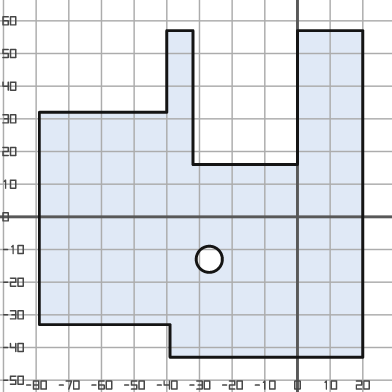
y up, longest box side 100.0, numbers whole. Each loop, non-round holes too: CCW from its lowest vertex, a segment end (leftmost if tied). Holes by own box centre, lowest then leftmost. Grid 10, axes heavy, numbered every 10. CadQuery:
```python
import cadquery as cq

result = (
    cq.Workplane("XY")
    .moveTo(-39.0, -43.0)
    .lineTo(20.0, -43.0)
    .lineTo(20.0, 57.0)
    .lineTo(0.0, 57.0)
    .lineTo(0.0, 16.0)
    .lineTo(-32.0, 16.0)
    .lineTo(-32.0, 57.0)
    .lineTo(-40.0, 57.0)
    .lineTo(-40.0, 32.0)
    .lineTo(-79.0, 32.0)
    .lineTo(-79.0, -33.0)
    .lineTo(-39.0, -33.0)
    .close()
    .moveTo(-27.0, -13.0)
    .circle(4.0)
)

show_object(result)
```